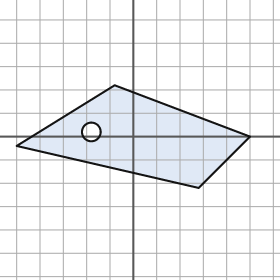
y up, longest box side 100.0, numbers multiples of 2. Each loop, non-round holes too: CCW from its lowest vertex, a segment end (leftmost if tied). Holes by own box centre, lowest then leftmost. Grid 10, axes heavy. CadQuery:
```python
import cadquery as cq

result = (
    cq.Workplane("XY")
    .moveTo(28.0, -22.0)
    .lineTo(50.0, 0.0)
    .lineTo(-8.0, 22.0)
    .lineTo(-50.0, -4.0)
    .close()
    .moveTo(-18.0, 2.0)
    .circle(4.0)
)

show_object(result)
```